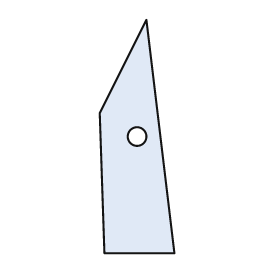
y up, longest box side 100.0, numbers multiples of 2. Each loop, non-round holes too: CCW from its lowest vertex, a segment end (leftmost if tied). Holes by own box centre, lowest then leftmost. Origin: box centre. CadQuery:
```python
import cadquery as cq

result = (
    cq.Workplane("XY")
    .moveTo(-14.0, -50.0)
    .lineTo(16.0, -50.0)
    .lineTo(4.0, 50.0)
    .lineTo(-16.0, 10.0)
    .close()
    .moveTo(0.0, 0.0)
    .circle(4.0)
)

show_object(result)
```